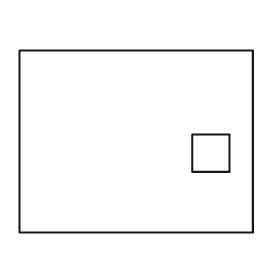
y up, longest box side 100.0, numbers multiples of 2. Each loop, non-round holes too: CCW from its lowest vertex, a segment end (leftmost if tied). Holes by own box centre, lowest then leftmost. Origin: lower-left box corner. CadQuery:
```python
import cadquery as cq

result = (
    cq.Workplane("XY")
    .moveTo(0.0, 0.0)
    .lineTo(100.0, 0.0)
    .lineTo(100.0, 78.0)
    .lineTo(0.0, 78.0)
    .close()
    .moveTo(74.0, 26.0)
    .lineTo(90.0, 26.0)
    .lineTo(90.0, 42.0)
    .lineTo(74.0, 42.0)
    .close()
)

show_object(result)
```